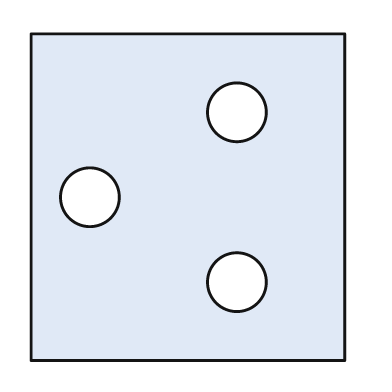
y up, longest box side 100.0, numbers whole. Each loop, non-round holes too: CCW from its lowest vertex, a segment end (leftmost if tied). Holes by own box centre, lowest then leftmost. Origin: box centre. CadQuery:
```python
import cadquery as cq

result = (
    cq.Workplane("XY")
    .moveTo(-48.0, -50.0)
    .lineTo(48.0, -50.0)
    .lineTo(48.0, 50.0)
    .lineTo(-48.0, 50.0)
    .close()
    .moveTo(15.0, -26.0)
    .circle(9.0)
    .moveTo(-30.0, 0.0)
    .circle(9.0)
    .moveTo(15.0, 26.0)
    .circle(9.0)
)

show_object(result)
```